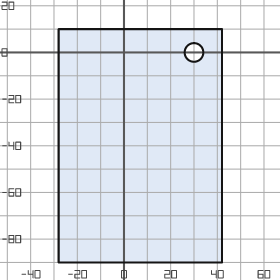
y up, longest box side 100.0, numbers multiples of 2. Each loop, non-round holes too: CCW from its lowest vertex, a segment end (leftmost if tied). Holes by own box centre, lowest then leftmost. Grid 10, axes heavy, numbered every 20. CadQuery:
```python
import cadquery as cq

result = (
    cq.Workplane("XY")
    .moveTo(-28.0, -90.0)
    .lineTo(42.0, -90.0)
    .lineTo(42.0, 10.0)
    .lineTo(-28.0, 10.0)
    .close()
    .moveTo(30.0, 0.0)
    .circle(4.0)
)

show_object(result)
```